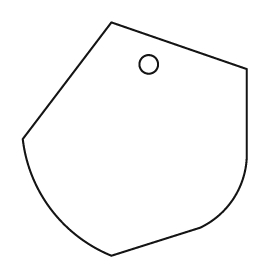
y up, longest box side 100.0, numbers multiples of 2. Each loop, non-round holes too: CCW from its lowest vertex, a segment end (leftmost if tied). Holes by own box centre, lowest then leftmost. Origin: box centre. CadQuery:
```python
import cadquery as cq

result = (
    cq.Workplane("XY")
    .moveTo(-10.0, -50.0)
    .lineTo(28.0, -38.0)
    .threePointArc((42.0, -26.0), (48.0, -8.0))
    .lineTo(48.0, 30.0)
    .lineTo(-10.0, 50.0)
    .lineTo(-48.0, 0.0)
    .threePointArc((-36.0, -30.0), (-10.0, -50.0))
    .close()
    .moveTo(6.0, 32.0)
    .circle(4.0)
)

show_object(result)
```